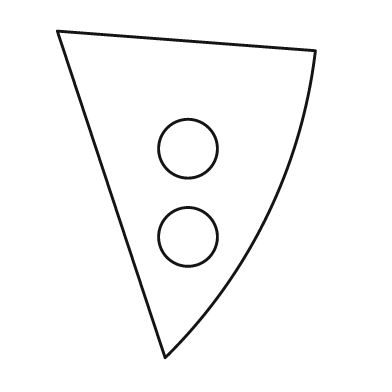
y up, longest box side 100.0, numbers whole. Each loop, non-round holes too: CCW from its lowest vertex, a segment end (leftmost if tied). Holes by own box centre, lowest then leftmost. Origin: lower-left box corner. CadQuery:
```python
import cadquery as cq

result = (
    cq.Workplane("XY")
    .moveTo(33.0, 0.0)
    .threePointArc((64.0, 43.0), (79.0, 94.0))
    .lineTo(0.0, 100.0)
    .close()
    .moveTo(40.0, 37.0)
    .circle(9.0)
    .moveTo(40.0, 64.0)
    .circle(9.0)
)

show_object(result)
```